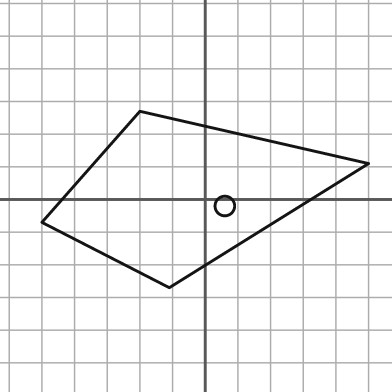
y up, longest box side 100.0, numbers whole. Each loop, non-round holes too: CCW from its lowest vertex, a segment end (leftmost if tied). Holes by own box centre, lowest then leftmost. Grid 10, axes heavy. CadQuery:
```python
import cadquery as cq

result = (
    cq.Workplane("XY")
    .moveTo(-11.0, -27.0)
    .lineTo(50.0, 11.0)
    .lineTo(-20.0, 27.0)
    .lineTo(-50.0, -7.0)
    .close()
    .moveTo(6.0, -2.0)
    .circle(3.0)
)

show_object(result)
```